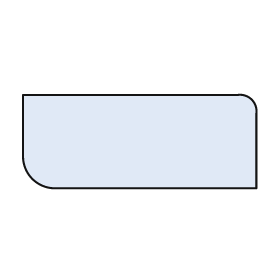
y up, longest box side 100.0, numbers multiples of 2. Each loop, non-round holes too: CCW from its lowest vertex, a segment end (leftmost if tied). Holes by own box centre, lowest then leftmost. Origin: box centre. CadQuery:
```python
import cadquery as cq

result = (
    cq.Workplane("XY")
    .moveTo(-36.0, -20.0)
    .lineTo(50.0, -20.0)
    .lineTo(50.0, 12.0)
    .threePointArc((48.0, 18.0), (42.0, 20.0))
    .lineTo(-50.0, 20.0)
    .lineTo(-50.0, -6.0)
    .threePointArc((-46.0, -16.0), (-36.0, -20.0))
    .close()
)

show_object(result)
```